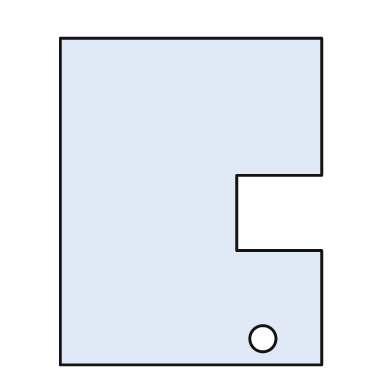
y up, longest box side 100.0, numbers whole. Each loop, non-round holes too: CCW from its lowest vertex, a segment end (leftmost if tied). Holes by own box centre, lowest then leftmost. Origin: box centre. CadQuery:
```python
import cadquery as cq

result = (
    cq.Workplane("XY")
    .moveTo(-40.0, -50.0)
    .lineTo(40.0, -50.0)
    .lineTo(40.0, -15.0)
    .lineTo(14.0, -15.0)
    .lineTo(14.0, 8.0)
    .lineTo(40.0, 8.0)
    .lineTo(40.0, 50.0)
    .lineTo(-40.0, 50.0)
    .close()
    .moveTo(22.0, -42.0)
    .circle(4.0)
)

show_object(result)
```